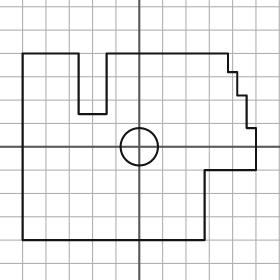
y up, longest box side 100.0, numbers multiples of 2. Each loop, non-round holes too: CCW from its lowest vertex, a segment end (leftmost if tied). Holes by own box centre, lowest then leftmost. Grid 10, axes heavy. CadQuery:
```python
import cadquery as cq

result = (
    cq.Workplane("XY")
    .moveTo(-50.0, -40.0)
    .lineTo(28.0, -40.0)
    .lineTo(28.0, -10.0)
    .lineTo(50.0, -10.0)
    .lineTo(50.0, 8.0)
    .lineTo(46.0, 8.0)
    .lineTo(46.0, 22.0)
    .lineTo(42.0, 22.0)
    .lineTo(42.0, 32.0)
    .lineTo(38.0, 32.0)
    .lineTo(38.0, 40.0)
    .lineTo(-14.0, 40.0)
    .lineTo(-14.0, 14.0)
    .lineTo(-26.0, 14.0)
    .lineTo(-26.0, 40.0)
    .lineTo(-50.0, 40.0)
    .close()
    .moveTo(0.0, 0.0)
    .circle(8.0)
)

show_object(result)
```